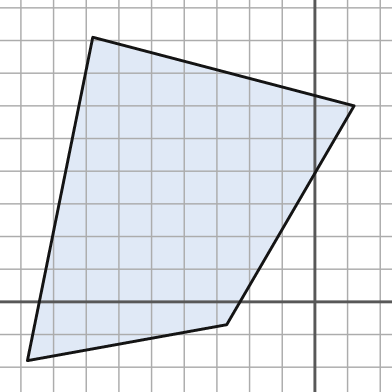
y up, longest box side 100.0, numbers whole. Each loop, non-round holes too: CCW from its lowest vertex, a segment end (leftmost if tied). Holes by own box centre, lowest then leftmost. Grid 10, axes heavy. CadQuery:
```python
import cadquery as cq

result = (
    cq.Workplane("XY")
    .moveTo(-88.0, -18.0)
    .lineTo(-27.0, -7.0)
    .lineTo(12.0, 60.0)
    .lineTo(-68.0, 81.0)
    .close()
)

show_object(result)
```